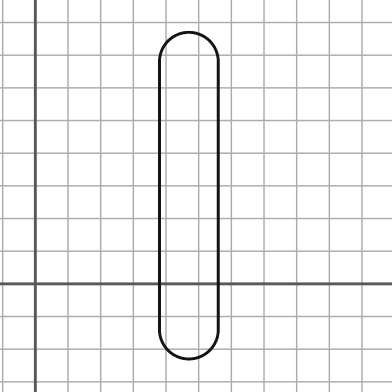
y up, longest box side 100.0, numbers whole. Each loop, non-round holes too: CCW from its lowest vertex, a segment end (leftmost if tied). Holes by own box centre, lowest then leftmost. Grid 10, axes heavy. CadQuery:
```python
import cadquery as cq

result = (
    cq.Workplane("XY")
    .moveTo(38.0, -14.0)
    .threePointArc((47.0, -23.0), (56.0, -14.0))
    .lineTo(56.0, 68.0)
    .threePointArc((47.0, 77.0), (38.0, 68.0))
    .close()
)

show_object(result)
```